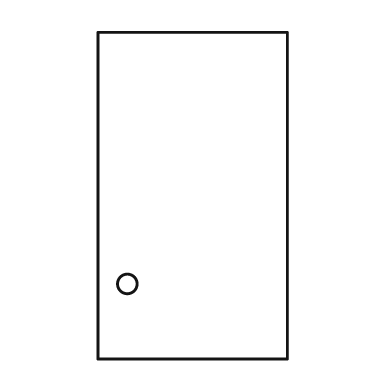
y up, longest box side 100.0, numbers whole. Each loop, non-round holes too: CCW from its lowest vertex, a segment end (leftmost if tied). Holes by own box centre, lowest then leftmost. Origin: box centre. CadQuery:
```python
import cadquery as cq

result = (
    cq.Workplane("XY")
    .moveTo(-29.0, -50.0)
    .lineTo(29.0, -50.0)
    .lineTo(29.0, 50.0)
    .lineTo(-29.0, 50.0)
    .close()
    .moveTo(-20.0, -27.0)
    .circle(3.0)
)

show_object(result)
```